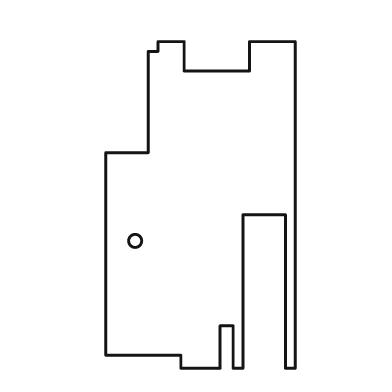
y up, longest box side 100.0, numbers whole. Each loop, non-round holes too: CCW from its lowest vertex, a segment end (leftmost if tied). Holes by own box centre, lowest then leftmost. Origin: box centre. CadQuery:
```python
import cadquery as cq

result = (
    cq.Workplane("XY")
    .moveTo(-6.0, -50.0)
    .lineTo(6.0, -50.0)
    .lineTo(6.0, -37.0)
    .lineTo(10.0, -37.0)
    .lineTo(10.0, -50.0)
    .lineTo(13.0, -50.0)
    .lineTo(13.0, -3.0)
    .lineTo(26.0, -3.0)
    .lineTo(26.0, -50.0)
    .lineTo(29.0, -50.0)
    .lineTo(29.0, 50.0)
    .lineTo(15.0, 50.0)
    .lineTo(15.0, 41.0)
    .lineTo(-5.0, 41.0)
    .lineTo(-5.0, 50.0)
    .lineTo(-13.0, 50.0)
    .lineTo(-13.0, 47.0)
    .lineTo(-16.0, 47.0)
    .lineTo(-16.0, 16.0)
    .lineTo(-29.0, 16.0)
    .lineTo(-29.0, -46.0)
    .lineTo(-6.0, -46.0)
    .close()
    .moveTo(-20.0, -11.0)
    .circle(2.0)
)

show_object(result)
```